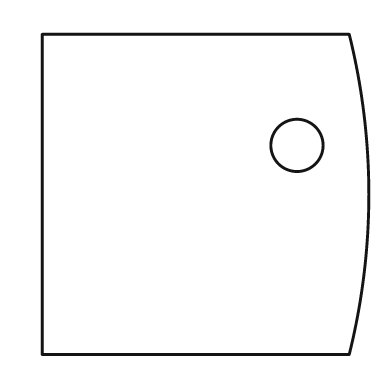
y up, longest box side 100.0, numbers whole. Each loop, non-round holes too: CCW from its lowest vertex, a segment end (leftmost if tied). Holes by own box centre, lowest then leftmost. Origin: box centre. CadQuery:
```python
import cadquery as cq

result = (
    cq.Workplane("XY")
    .moveTo(-50.0, -49.0)
    .lineTo(44.0, -49.0)
    .threePointArc((50.0, 0.0), (44.0, 49.0))
    .lineTo(-50.0, 49.0)
    .close()
    .moveTo(28.0, 15.0)
    .circle(8.0)
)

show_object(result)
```